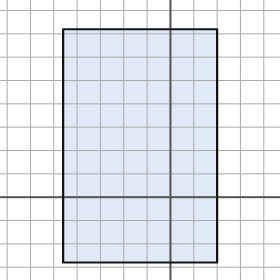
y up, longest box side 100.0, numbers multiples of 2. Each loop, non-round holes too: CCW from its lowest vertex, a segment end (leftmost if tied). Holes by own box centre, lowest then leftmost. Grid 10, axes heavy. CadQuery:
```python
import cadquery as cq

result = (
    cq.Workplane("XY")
    .moveTo(-46.0, -28.0)
    .lineTo(20.0, -28.0)
    .lineTo(20.0, 72.0)
    .lineTo(-46.0, 72.0)
    .close()
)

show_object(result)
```